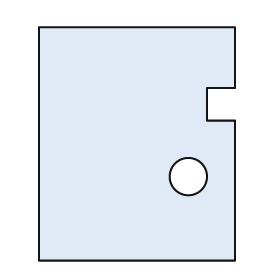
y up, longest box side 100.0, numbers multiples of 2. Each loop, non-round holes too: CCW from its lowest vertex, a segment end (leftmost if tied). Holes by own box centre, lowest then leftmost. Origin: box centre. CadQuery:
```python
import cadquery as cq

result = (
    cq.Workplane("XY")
    .moveTo(-42.0, -50.0)
    .lineTo(42.0, -50.0)
    .lineTo(42.0, 10.0)
    .lineTo(30.0, 10.0)
    .lineTo(30.0, 24.0)
    .lineTo(42.0, 24.0)
    .lineTo(42.0, 50.0)
    .lineTo(-42.0, 50.0)
    .close()
    .moveTo(22.0, -14.0)
    .circle(8.0)
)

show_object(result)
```